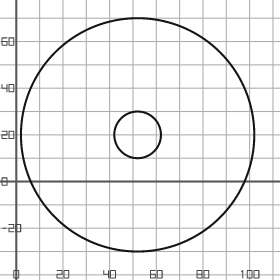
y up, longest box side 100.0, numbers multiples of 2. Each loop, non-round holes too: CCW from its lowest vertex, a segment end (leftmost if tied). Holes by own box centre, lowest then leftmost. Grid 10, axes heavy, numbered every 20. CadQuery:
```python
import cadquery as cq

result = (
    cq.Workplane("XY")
    .moveTo(52.0, 20.0)
    .circle(50.0)
    .moveTo(52.0, 20.0)
    .circle(10.0)
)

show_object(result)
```